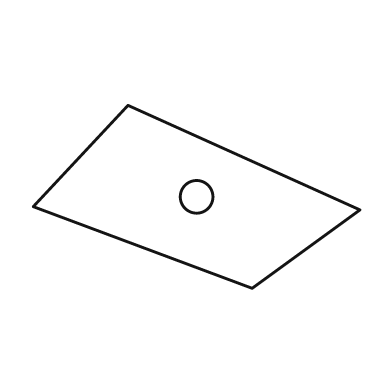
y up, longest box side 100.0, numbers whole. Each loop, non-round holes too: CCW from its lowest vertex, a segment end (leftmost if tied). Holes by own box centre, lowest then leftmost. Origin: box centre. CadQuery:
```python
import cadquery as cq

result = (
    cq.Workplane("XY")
    .moveTo(17.0, -28.0)
    .lineTo(50.0, -4.0)
    .lineTo(-21.0, 28.0)
    .lineTo(-50.0, -3.0)
    .close()
    .moveTo(0.0, 0.0)
    .circle(5.0)
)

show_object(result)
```